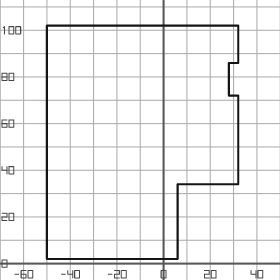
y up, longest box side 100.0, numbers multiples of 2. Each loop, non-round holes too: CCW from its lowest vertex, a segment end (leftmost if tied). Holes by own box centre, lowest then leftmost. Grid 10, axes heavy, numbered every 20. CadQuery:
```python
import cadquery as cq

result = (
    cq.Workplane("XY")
    .moveTo(-50.0, 2.0)
    .lineTo(6.0, 2.0)
    .lineTo(6.0, 34.0)
    .lineTo(32.0, 34.0)
    .lineTo(32.0, 72.0)
    .lineTo(28.0, 72.0)
    .lineTo(28.0, 86.0)
    .lineTo(32.0, 86.0)
    .lineTo(32.0, 102.0)
    .lineTo(-50.0, 102.0)
    .close()
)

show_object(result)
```